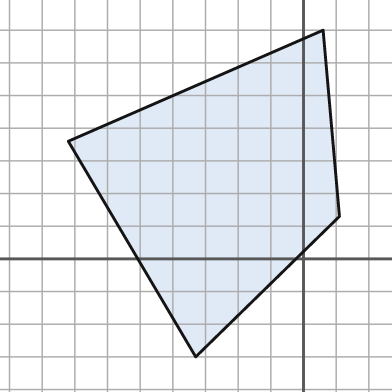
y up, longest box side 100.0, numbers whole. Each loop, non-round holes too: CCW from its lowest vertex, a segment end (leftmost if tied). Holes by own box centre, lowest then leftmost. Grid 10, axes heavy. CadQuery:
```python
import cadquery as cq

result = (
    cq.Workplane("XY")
    .moveTo(-33.0, -30.0)
    .lineTo(11.0, 13.0)
    .lineTo(6.0, 70.0)
    .lineTo(-72.0, 36.0)
    .close()
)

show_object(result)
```